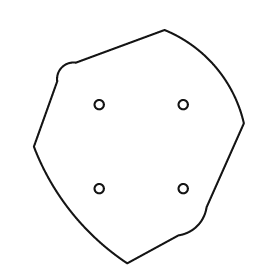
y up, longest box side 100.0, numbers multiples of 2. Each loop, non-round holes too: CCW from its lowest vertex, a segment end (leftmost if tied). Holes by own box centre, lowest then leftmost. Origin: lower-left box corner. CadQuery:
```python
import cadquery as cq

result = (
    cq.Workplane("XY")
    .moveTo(40.0, 0.0)
    .lineTo(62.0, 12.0)
    .threePointArc((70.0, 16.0), (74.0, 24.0))
    .lineTo(90.0, 60.0)
    .threePointArc((78.0, 84.0), (56.0, 100.0))
    .lineTo(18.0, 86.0)
    .threePointArc((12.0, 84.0), (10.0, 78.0))
    .lineTo(0.0, 50.0)
    .threePointArc((16.0, 22.0), (40.0, 0.0))
    .close()
    .moveTo(28.0, 32.0)
    .circle(2.0)
    .moveTo(64.0, 32.0)
    .circle(2.0)
    .moveTo(28.0, 68.0)
    .circle(2.0)
    .moveTo(64.0, 68.0)
    .circle(2.0)
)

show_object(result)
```